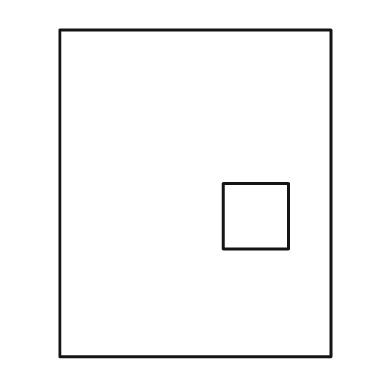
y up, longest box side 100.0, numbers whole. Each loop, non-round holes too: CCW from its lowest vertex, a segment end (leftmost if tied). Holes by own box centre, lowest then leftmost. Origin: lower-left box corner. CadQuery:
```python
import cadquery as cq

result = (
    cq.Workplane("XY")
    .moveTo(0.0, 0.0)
    .lineTo(83.0, 0.0)
    .lineTo(83.0, 100.0)
    .lineTo(0.0, 100.0)
    .close()
    .moveTo(50.0, 33.0)
    .lineTo(70.0, 33.0)
    .lineTo(70.0, 53.0)
    .lineTo(50.0, 53.0)
    .close()
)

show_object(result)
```